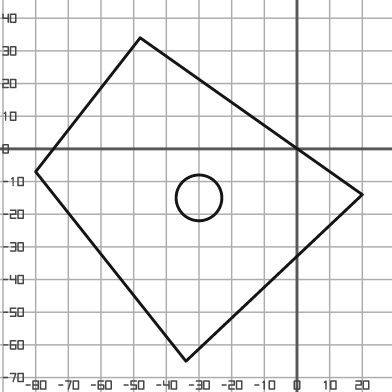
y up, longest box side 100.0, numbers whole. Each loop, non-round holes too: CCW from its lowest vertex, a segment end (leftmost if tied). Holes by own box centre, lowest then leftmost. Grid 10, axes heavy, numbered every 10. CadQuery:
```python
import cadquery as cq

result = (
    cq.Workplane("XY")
    .moveTo(-34.0, -65.0)
    .lineTo(20.0, -14.0)
    .lineTo(-48.0, 34.0)
    .lineTo(-80.0, -7.0)
    .close()
    .moveTo(-30.0, -15.0)
    .circle(7.0)
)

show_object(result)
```